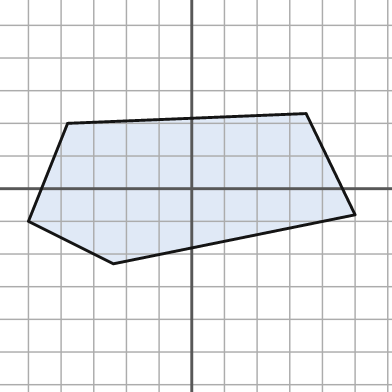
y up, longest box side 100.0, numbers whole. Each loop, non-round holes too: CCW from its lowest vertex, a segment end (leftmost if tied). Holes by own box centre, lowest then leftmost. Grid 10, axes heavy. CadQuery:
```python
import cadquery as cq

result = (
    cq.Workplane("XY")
    .moveTo(-24.0, -23.0)
    .lineTo(50.0, -8.0)
    .lineTo(35.0, 23.0)
    .lineTo(-38.0, 20.0)
    .lineTo(-50.0, -10.0)
    .close()
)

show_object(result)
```